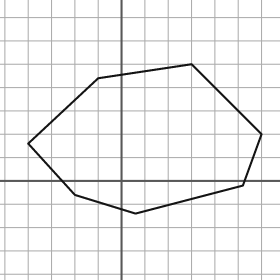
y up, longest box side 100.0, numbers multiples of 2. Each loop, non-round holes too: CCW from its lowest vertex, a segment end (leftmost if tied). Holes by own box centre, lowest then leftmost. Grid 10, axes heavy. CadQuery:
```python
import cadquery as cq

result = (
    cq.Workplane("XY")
    .moveTo(6.0, -14.0)
    .lineTo(52.0, -2.0)
    .lineTo(60.0, 20.0)
    .lineTo(30.0, 50.0)
    .lineTo(-10.0, 44.0)
    .lineTo(-40.0, 16.0)
    .lineTo(-20.0, -6.0)
    .close()
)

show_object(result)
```